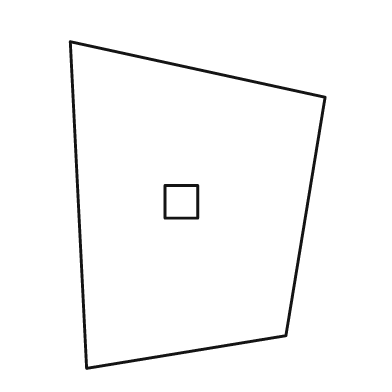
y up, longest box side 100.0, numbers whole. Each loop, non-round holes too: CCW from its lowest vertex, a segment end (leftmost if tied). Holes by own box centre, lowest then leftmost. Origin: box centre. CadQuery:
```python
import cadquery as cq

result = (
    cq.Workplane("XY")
    .moveTo(-34.0, -50.0)
    .lineTo(27.0, -40.0)
    .lineTo(39.0, 33.0)
    .lineTo(-39.0, 50.0)
    .close()
    .moveTo(-10.0, -4.0)
    .lineTo(0.0, -4.0)
    .lineTo(0.0, 6.0)
    .lineTo(-10.0, 6.0)
    .close()
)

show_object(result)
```